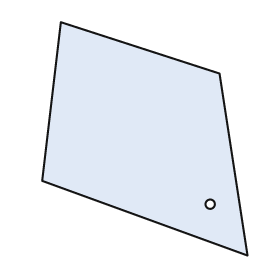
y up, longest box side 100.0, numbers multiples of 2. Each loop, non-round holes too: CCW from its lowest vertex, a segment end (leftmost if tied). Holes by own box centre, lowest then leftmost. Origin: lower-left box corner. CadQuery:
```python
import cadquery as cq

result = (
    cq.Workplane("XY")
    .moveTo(88.0, 0.0)
    .lineTo(76.0, 78.0)
    .lineTo(8.0, 100.0)
    .lineTo(0.0, 32.0)
    .close()
    .moveTo(72.0, 22.0)
    .circle(2.0)
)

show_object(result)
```